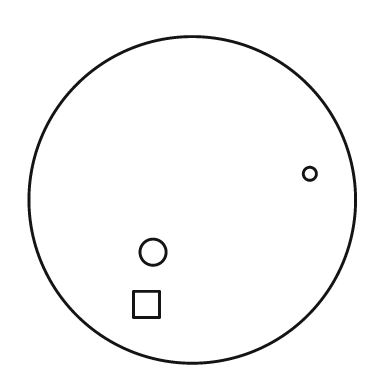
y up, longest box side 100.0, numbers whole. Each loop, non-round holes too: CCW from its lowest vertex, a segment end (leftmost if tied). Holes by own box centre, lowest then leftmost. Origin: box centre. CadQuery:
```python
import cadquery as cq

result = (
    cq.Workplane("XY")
    .moveTo(0.0, 0.0)
    .circle(50.0)
    .moveTo(-18.0, -36.0)
    .lineTo(-10.0, -36.0)
    .lineTo(-10.0, -28.0)
    .lineTo(-18.0, -28.0)
    .close()
    .moveTo(-12.0, -16.0)
    .circle(4.0)
    .moveTo(36.0, 8.0)
    .circle(2.0)
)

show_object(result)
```